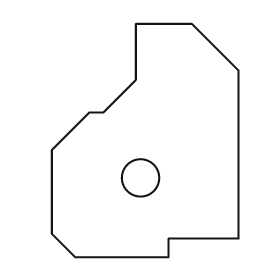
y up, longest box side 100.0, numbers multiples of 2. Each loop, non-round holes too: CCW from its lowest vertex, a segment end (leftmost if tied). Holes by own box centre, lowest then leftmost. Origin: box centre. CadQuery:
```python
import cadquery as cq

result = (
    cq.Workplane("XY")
    .moveTo(-30.0, -50.0)
    .lineTo(10.0, -50.0)
    .lineTo(10.0, -42.0)
    .lineTo(40.0, -42.0)
    .lineTo(40.0, 30.0)
    .lineTo(20.0, 50.0)
    .lineTo(-4.0, 50.0)
    .lineTo(-4.0, 26.0)
    .lineTo(-18.0, 12.0)
    .lineTo(-24.0, 12.0)
    .lineTo(-40.0, -4.0)
    .lineTo(-40.0, -40.0)
    .close()
    .moveTo(-2.0, -16.0)
    .circle(8.0)
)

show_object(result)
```